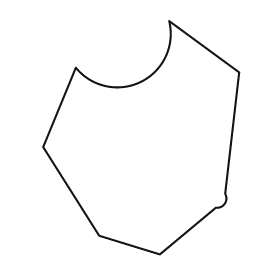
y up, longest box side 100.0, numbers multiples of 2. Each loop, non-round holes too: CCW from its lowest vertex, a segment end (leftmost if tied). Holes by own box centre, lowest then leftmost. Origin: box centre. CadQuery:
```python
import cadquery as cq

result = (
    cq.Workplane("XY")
    .moveTo(8.0, -50.0)
    .lineTo(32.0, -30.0)
    .threePointArc((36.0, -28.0), (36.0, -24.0))
    .lineTo(42.0, 28.0)
    .lineTo(12.0, 50.0)
    .threePointArc((0.0, 24.0), (-28.0, 30.0))
    .lineTo(-42.0, -4.0)
    .lineTo(-18.0, -42.0)
    .close()
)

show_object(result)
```